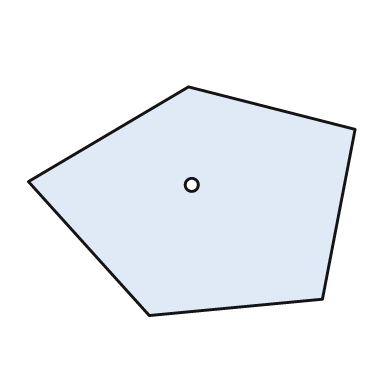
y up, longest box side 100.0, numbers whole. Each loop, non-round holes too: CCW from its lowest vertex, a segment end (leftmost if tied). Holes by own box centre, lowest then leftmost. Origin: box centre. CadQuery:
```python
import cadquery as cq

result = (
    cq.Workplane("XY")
    .moveTo(-13.0, -35.0)
    .lineTo(40.0, -30.0)
    .lineTo(50.0, 22.0)
    .lineTo(-1.0, 35.0)
    .lineTo(-50.0, 6.0)
    .close()
    .moveTo(0.0, 5.0)
    .circle(2.0)
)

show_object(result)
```